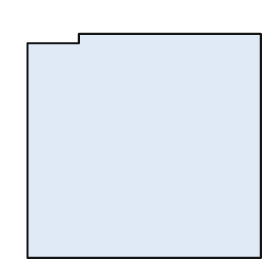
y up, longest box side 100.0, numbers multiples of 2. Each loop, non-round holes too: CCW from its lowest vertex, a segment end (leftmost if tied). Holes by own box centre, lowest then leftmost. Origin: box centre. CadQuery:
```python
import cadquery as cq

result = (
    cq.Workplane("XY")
    .moveTo(-50.0, -48.0)
    .lineTo(50.0, -48.0)
    .lineTo(50.0, 48.0)
    .lineTo(-28.0, 48.0)
    .lineTo(-28.0, 44.0)
    .lineTo(-50.0, 44.0)
    .close()
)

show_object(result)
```